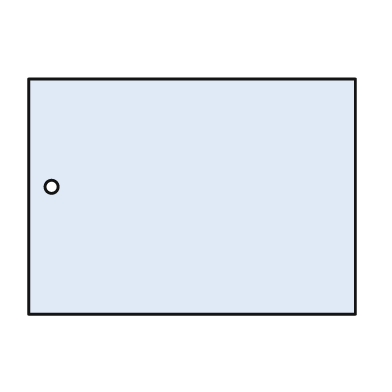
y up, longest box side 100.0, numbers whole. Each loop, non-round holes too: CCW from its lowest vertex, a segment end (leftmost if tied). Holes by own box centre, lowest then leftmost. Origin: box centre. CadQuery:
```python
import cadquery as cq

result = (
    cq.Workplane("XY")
    .moveTo(-50.0, -36.0)
    .lineTo(50.0, -36.0)
    .lineTo(50.0, 36.0)
    .lineTo(-50.0, 36.0)
    .close()
    .moveTo(-43.0, 3.0)
    .circle(2.0)
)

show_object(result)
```